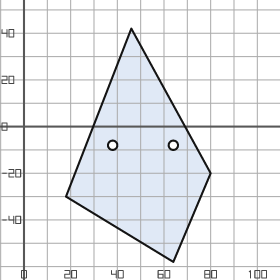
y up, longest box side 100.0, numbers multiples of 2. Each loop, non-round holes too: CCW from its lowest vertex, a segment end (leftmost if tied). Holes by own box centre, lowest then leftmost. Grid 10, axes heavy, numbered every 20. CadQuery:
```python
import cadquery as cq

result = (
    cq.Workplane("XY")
    .moveTo(64.0, -58.0)
    .lineTo(80.0, -20.0)
    .lineTo(46.0, 42.0)
    .lineTo(18.0, -30.0)
    .close()
    .moveTo(38.0, -8.0)
    .circle(2.0)
    .moveTo(64.0, -8.0)
    .circle(2.0)
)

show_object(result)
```